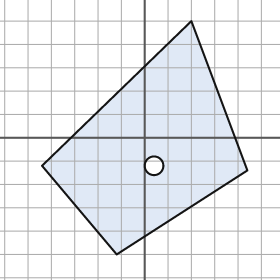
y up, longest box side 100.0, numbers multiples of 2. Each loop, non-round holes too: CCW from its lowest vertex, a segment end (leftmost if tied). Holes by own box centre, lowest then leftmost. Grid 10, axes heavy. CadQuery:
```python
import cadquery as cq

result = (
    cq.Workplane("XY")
    .moveTo(-12.0, -50.0)
    .lineTo(44.0, -14.0)
    .lineTo(20.0, 50.0)
    .lineTo(-44.0, -12.0)
    .close()
    .moveTo(4.0, -12.0)
    .circle(4.0)
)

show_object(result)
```